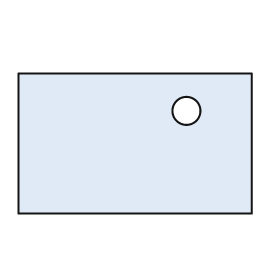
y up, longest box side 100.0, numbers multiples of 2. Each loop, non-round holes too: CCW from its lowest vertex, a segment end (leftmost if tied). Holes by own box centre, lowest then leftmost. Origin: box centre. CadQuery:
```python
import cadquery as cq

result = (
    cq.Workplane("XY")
    .moveTo(-50.0, -30.0)
    .lineTo(50.0, -30.0)
    .lineTo(50.0, 30.0)
    .lineTo(-50.0, 30.0)
    .close()
    .moveTo(22.0, 14.0)
    .circle(6.0)
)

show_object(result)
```